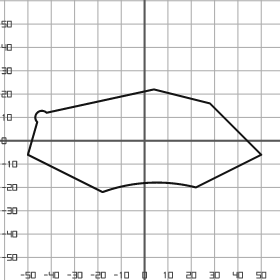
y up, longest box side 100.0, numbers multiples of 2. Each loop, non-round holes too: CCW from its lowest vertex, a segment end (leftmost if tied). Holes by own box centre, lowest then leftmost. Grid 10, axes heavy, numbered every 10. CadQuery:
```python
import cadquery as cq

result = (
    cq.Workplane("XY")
    .moveTo(-18.0, -22.0)
    .threePointArc((2.0, -18.0), (22.0, -20.0))
    .lineTo(50.0, -6.0)
    .lineTo(28.0, 16.0)
    .lineTo(4.0, 22.0)
    .lineTo(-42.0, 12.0)
    .threePointArc((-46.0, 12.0), (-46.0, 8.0))
    .lineTo(-50.0, -6.0)
    .close()
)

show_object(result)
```